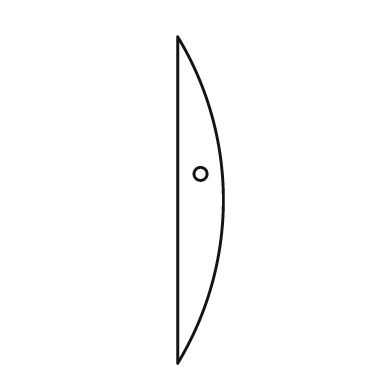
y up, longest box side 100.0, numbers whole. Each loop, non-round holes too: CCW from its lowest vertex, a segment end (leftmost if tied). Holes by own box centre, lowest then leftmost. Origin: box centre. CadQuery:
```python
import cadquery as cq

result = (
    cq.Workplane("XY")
    .moveTo(-7.0, -50.0)
    .threePointArc((7.0, 0.0), (-7.0, 50.0))
    .close()
    .moveTo(0.0, 8.0)
    .circle(2.0)
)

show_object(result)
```